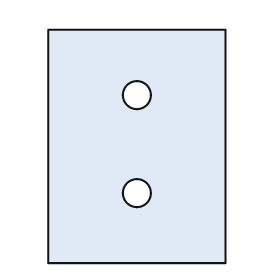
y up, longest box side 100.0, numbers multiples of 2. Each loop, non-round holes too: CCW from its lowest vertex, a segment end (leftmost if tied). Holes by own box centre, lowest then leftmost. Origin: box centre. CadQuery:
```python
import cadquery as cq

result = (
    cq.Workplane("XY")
    .moveTo(-38.0, -50.0)
    .lineTo(38.0, -50.0)
    .lineTo(38.0, 50.0)
    .lineTo(-38.0, 50.0)
    .close()
    .moveTo(0.0, -20.0)
    .circle(6.0)
    .moveTo(0.0, 22.0)
    .circle(6.0)
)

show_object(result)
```